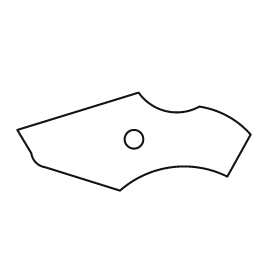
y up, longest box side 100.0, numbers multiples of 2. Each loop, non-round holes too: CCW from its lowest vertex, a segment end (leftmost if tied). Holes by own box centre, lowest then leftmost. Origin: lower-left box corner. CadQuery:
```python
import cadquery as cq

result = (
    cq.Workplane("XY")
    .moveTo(44.0, 0.0)
    .threePointArc((66.0, 10.0), (90.0, 6.0))
    .lineTo(100.0, 24.0)
    .threePointArc((90.0, 32.0), (78.0, 36.0))
    .threePointArc((64.0, 34.0), (52.0, 42.0))
    .lineTo(0.0, 26.0)
    .lineTo(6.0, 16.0)
    .threePointArc((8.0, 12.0), (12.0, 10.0))
    .close()
    .moveTo(50.0, 22.0)
    .circle(4.0)
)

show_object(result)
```